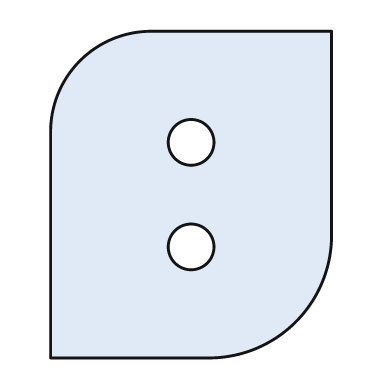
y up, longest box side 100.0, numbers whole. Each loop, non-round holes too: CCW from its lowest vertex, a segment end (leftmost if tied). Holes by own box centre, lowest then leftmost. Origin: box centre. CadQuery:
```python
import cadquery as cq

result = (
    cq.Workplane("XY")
    .moveTo(-43.0, -50.0)
    .lineTo(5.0, -50.0)
    .threePointArc((32.0, -39.0), (43.0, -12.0))
    .lineTo(43.0, 50.0)
    .lineTo(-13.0, 50.0)
    .threePointArc((-34.0, 41.0), (-43.0, 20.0))
    .close()
    .moveTo(0.0, -16.0)
    .circle(7.0)
    .moveTo(0.0, 16.0)
    .circle(7.0)
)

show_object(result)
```